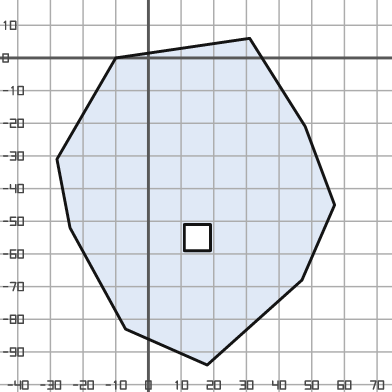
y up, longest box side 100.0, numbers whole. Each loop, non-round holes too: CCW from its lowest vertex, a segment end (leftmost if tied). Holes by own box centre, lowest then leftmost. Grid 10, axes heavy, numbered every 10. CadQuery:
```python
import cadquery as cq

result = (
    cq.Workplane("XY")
    .moveTo(18.0, -94.0)
    .lineTo(47.0, -68.0)
    .lineTo(57.0, -45.0)
    .lineTo(48.0, -21.0)
    .lineTo(31.0, 6.0)
    .lineTo(-10.0, 0.0)
    .lineTo(-28.0, -31.0)
    .lineTo(-24.0, -52.0)
    .lineTo(-7.0, -83.0)
    .close()
    .moveTo(11.0, -59.0)
    .lineTo(19.0, -59.0)
    .lineTo(19.0, -51.0)
    .lineTo(11.0, -51.0)
    .close()
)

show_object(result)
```